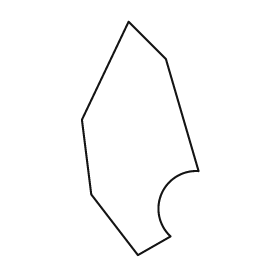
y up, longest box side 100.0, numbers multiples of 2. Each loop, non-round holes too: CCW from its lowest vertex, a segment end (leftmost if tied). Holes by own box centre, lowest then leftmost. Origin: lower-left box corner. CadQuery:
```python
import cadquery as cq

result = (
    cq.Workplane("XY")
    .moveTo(24.0, 0.0)
    .lineTo(38.0, 8.0)
    .threePointArc((34.0, 26.0), (50.0, 36.0))
    .lineTo(36.0, 84.0)
    .lineTo(20.0, 100.0)
    .lineTo(0.0, 58.0)
    .lineTo(4.0, 26.0)
    .close()
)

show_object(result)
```